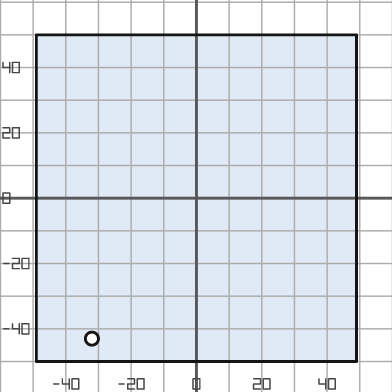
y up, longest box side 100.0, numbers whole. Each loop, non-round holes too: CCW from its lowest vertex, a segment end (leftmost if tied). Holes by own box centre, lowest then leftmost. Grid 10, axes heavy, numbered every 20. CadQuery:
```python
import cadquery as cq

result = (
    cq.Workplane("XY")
    .moveTo(-49.0, -50.0)
    .lineTo(49.0, -50.0)
    .lineTo(49.0, 50.0)
    .lineTo(-49.0, 50.0)
    .close()
    .moveTo(-32.0, -43.0)
    .circle(2.0)
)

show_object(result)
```